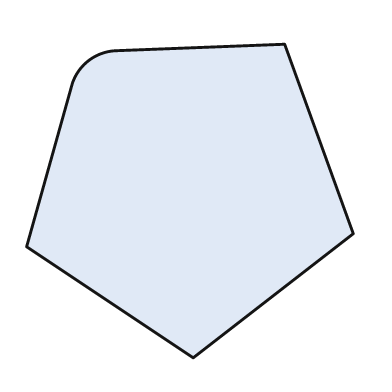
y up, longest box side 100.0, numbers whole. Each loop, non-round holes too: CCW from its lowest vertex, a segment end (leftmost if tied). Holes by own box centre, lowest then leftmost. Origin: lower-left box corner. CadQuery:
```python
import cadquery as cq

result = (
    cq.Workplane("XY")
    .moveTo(51.0, 0.0)
    .lineTo(100.0, 38.0)
    .lineTo(79.0, 96.0)
    .lineTo(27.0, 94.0)
    .threePointArc((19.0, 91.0), (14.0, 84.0))
    .lineTo(0.0, 34.0)
    .close()
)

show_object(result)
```